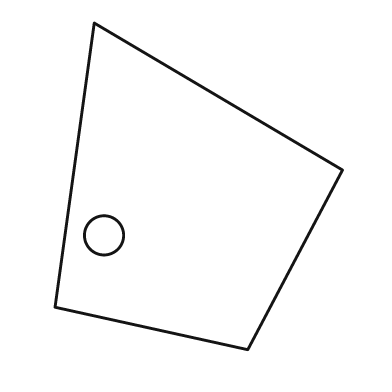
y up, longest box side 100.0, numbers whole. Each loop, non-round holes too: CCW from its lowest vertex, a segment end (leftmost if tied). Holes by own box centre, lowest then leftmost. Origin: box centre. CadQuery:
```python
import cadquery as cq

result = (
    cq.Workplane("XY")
    .moveTo(15.0, -50.0)
    .lineTo(44.0, 5.0)
    .lineTo(-32.0, 50.0)
    .lineTo(-44.0, -37.0)
    .close()
    .moveTo(-29.0, -15.0)
    .circle(6.0)
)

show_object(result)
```